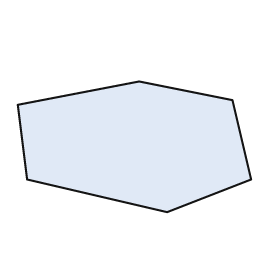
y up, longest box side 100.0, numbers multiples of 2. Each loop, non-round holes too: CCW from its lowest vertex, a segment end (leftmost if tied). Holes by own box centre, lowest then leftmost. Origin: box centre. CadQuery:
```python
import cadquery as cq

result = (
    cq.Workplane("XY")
    .moveTo(14.0, -28.0)
    .lineTo(50.0, -14.0)
    .lineTo(42.0, 20.0)
    .lineTo(2.0, 28.0)
    .lineTo(-50.0, 18.0)
    .lineTo(-46.0, -14.0)
    .close()
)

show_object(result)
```